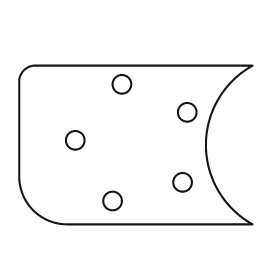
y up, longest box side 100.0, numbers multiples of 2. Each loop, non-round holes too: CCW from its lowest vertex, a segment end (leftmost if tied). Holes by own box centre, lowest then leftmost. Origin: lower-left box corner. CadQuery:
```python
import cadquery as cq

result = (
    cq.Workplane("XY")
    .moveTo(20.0, 0.0)
    .lineTo(100.0, 0.0)
    .threePointArc((80.0, 34.0), (100.0, 68.0))
    .lineTo(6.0, 68.0)
    .threePointArc((2.0, 66.0), (0.0, 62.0))
    .lineTo(0.0, 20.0)
    .threePointArc((6.0, 6.0), (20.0, 0.0))
    .close()
    .moveTo(40.0, 10.0)
    .circle(4.0)
    .moveTo(70.0, 18.0)
    .circle(4.0)
    .moveTo(24.0, 36.0)
    .circle(4.0)
    .moveTo(72.0, 48.0)
    .circle(4.0)
    .moveTo(44.0, 60.0)
    .circle(4.0)
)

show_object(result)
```